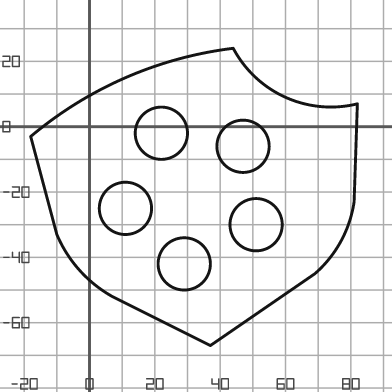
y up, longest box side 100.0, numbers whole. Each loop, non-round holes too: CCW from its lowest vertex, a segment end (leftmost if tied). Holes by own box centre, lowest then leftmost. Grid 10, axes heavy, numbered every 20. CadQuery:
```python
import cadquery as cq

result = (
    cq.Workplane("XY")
    .moveTo(37.0, -67.0)
    .lineTo(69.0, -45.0)
    .threePointArc((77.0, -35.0), (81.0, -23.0))
    .lineTo(82.0, 7.0)
    .threePointArc((60.0, 9.0), (44.0, 24.0))
    .threePointArc((11.0, 15.0), (-18.0, -3.0))
    .lineTo(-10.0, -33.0)
    .threePointArc((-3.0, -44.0), (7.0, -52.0))
    .close()
    .moveTo(29.0, -42.0)
    .circle(8.0)
    .moveTo(51.0, -30.0)
    .circle(8.0)
    .moveTo(11.0, -25.0)
    .circle(8.0)
    .moveTo(47.0, -6.0)
    .circle(8.0)
    .moveTo(22.0, -2.0)
    .circle(8.0)
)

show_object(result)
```